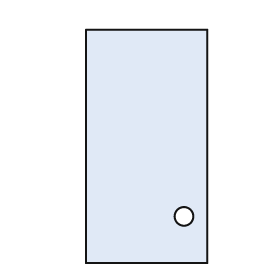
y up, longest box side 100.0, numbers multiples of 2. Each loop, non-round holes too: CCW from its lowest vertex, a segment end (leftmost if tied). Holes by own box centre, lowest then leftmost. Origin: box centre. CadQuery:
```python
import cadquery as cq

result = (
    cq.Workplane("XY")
    .moveTo(-26.0, -50.0)
    .lineTo(26.0, -50.0)
    .lineTo(26.0, 50.0)
    .lineTo(-26.0, 50.0)
    .close()
    .moveTo(16.0, -30.0)
    .circle(4.0)
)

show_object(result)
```